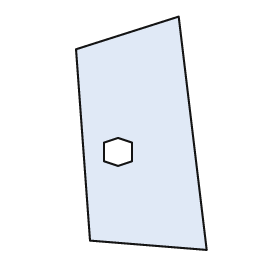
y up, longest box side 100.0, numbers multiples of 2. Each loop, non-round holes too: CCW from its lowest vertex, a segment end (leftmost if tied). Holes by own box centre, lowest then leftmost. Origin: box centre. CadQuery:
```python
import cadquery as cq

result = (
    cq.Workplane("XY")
    .moveTo(28.0, -50.0)
    .lineTo(16.0, 50.0)
    .lineTo(-28.0, 36.0)
    .lineTo(-22.0, -46.0)
    .close()
    .moveTo(-10.0, -14.0)
    .lineTo(-4.0, -12.0)
    .lineTo(-4.0, -4.0)
    .lineTo(-10.0, -2.0)
    .lineTo(-16.0, -4.0)
    .lineTo(-16.0, -12.0)
    .close()
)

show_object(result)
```